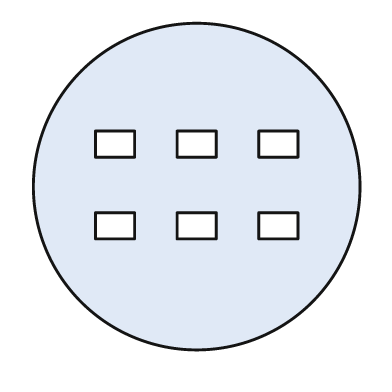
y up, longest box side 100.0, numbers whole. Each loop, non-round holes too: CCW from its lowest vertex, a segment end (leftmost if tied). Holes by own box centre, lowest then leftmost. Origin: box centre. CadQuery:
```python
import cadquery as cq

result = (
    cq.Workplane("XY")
    .moveTo(0.0, 0.0)
    .circle(50.0)
    .moveTo(-31.0, -16.0)
    .lineTo(-19.0, -16.0)
    .lineTo(-19.0, -8.0)
    .lineTo(-31.0, -8.0)
    .close()
    .moveTo(-6.0, -16.0)
    .lineTo(6.0, -16.0)
    .lineTo(6.0, -8.0)
    .lineTo(-6.0, -8.0)
    .close()
    .moveTo(19.0, -16.0)
    .lineTo(31.0, -16.0)
    .lineTo(31.0, -8.0)
    .lineTo(19.0, -8.0)
    .close()
    .moveTo(-31.0, 9.0)
    .lineTo(-19.0, 9.0)
    .lineTo(-19.0, 17.0)
    .lineTo(-31.0, 17.0)
    .close()
    .moveTo(-6.0, 9.0)
    .lineTo(6.0, 9.0)
    .lineTo(6.0, 17.0)
    .lineTo(-6.0, 17.0)
    .close()
    .moveTo(19.0, 9.0)
    .lineTo(31.0, 9.0)
    .lineTo(31.0, 17.0)
    .lineTo(19.0, 17.0)
    .close()
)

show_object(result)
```